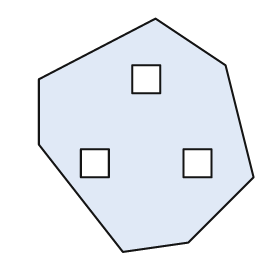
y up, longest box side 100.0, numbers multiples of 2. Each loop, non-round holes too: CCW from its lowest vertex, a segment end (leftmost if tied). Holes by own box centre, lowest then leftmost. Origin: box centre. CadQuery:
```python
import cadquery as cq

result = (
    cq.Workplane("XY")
    .moveTo(-10.0, -50.0)
    .lineTo(18.0, -46.0)
    .lineTo(46.0, -18.0)
    .lineTo(34.0, 30.0)
    .lineTo(4.0, 50.0)
    .lineTo(-46.0, 24.0)
    .lineTo(-46.0, -4.0)
    .close()
    .moveTo(-28.0, -18.0)
    .lineTo(-16.0, -18.0)
    .lineTo(-16.0, -6.0)
    .lineTo(-28.0, -6.0)
    .close()
    .moveTo(16.0, -18.0)
    .lineTo(28.0, -18.0)
    .lineTo(28.0, -6.0)
    .lineTo(16.0, -6.0)
    .close()
    .moveTo(-6.0, 18.0)
    .lineTo(6.0, 18.0)
    .lineTo(6.0, 30.0)
    .lineTo(-6.0, 30.0)
    .close()
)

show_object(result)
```